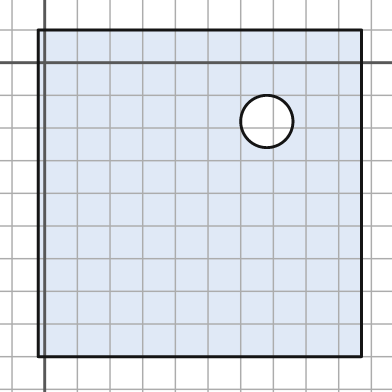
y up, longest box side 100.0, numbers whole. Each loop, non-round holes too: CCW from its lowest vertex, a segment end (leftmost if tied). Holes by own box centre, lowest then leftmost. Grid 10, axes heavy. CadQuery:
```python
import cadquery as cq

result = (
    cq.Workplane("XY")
    .moveTo(-2.0, -90.0)
    .lineTo(97.0, -90.0)
    .lineTo(97.0, 10.0)
    .lineTo(-2.0, 10.0)
    .close()
    .moveTo(68.0, -18.0)
    .circle(8.0)
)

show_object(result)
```